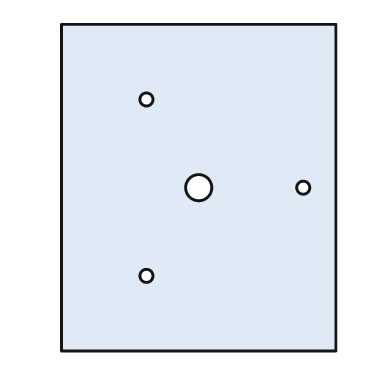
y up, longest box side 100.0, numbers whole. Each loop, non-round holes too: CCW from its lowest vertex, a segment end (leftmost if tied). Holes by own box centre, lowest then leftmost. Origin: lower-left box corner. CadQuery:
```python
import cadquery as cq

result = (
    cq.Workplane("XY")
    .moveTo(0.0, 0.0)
    .lineTo(84.0, 0.0)
    .lineTo(84.0, 100.0)
    .lineTo(0.0, 100.0)
    .close()
    .moveTo(26.0, 23.0)
    .circle(2.0)
    .moveTo(42.0, 50.0)
    .circle(4.0)
    .moveTo(74.0, 50.0)
    .circle(2.0)
    .moveTo(26.0, 77.0)
    .circle(2.0)
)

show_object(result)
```